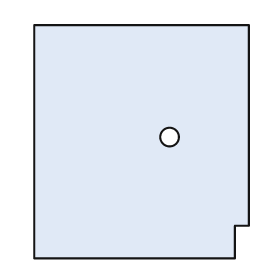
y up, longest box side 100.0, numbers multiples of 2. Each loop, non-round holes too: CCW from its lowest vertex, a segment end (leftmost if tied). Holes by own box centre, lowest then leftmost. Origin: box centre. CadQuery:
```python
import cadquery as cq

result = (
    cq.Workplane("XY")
    .moveTo(-46.0, -50.0)
    .lineTo(40.0, -50.0)
    .lineTo(40.0, -36.0)
    .lineTo(46.0, -36.0)
    .lineTo(46.0, 50.0)
    .lineTo(-46.0, 50.0)
    .close()
    .moveTo(12.0, 2.0)
    .circle(4.0)
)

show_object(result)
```